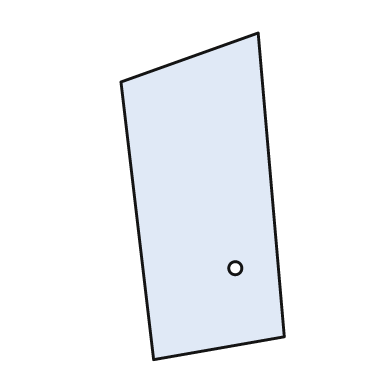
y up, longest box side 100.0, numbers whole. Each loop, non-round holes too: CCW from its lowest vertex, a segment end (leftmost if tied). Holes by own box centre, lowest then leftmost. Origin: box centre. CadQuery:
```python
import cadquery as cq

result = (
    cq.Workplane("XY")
    .moveTo(-15.0, -50.0)
    .lineTo(25.0, -43.0)
    .lineTo(17.0, 50.0)
    .lineTo(-25.0, 35.0)
    .close()
    .moveTo(10.0, -22.0)
    .circle(2.0)
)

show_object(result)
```